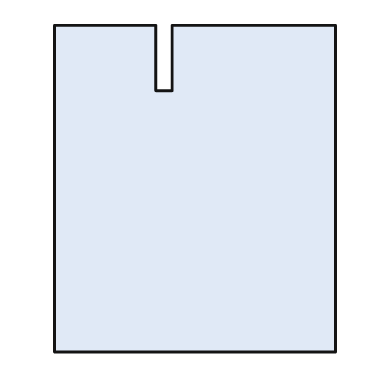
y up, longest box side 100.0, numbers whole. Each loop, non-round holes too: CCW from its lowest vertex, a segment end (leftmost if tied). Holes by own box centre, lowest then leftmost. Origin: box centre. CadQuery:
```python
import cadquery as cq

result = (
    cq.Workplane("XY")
    .moveTo(-43.0, -50.0)
    .lineTo(43.0, -50.0)
    .lineTo(43.0, 50.0)
    .lineTo(-7.0, 50.0)
    .lineTo(-7.0, 30.0)
    .lineTo(-12.0, 30.0)
    .lineTo(-12.0, 50.0)
    .lineTo(-43.0, 50.0)
    .close()
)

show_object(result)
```